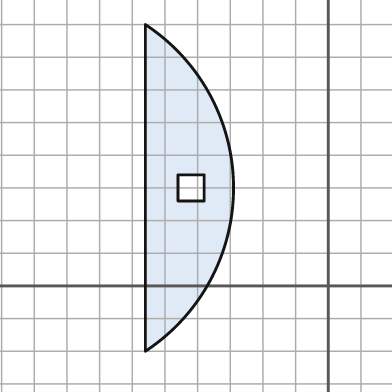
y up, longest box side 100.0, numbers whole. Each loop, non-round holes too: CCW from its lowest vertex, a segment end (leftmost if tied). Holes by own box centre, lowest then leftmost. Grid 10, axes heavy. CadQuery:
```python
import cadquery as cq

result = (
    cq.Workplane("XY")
    .moveTo(-56.0, -20.0)
    .threePointArc((-29.0, 30.0), (-56.0, 80.0))
    .close()
    .moveTo(-46.0, 26.0)
    .lineTo(-38.0, 26.0)
    .lineTo(-38.0, 34.0)
    .lineTo(-46.0, 34.0)
    .close()
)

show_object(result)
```